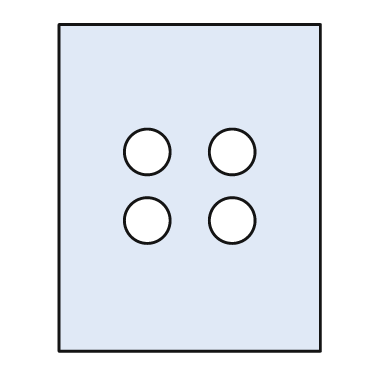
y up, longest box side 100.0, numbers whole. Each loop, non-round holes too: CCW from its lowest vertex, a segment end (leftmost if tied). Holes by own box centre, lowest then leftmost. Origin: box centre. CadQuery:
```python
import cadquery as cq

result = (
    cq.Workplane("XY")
    .moveTo(-40.0, -50.0)
    .lineTo(40.0, -50.0)
    .lineTo(40.0, 50.0)
    .lineTo(-40.0, 50.0)
    .close()
    .moveTo(-13.0, -10.0)
    .circle(7.0)
    .moveTo(13.0, -10.0)
    .circle(7.0)
    .moveTo(-13.0, 11.0)
    .circle(7.0)
    .moveTo(13.0, 11.0)
    .circle(7.0)
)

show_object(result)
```